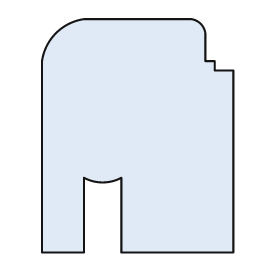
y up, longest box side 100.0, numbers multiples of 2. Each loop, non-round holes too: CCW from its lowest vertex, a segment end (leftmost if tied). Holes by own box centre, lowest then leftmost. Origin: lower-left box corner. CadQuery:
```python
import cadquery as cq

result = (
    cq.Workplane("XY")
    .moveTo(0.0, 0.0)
    .lineTo(18.0, 0.0)
    .lineTo(18.0, 32.0)
    .threePointArc((26.0, 30.0), (34.0, 32.0))
    .lineTo(34.0, 0.0)
    .lineTo(82.0, 0.0)
    .lineTo(82.0, 78.0)
    .lineTo(74.0, 78.0)
    .lineTo(74.0, 82.0)
    .lineTo(70.0, 82.0)
    .lineTo(70.0, 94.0)
    .threePointArc((68.0, 98.0), (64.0, 100.0))
    .lineTo(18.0, 100.0)
    .threePointArc((6.0, 94.0), (0.0, 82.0))
    .close()
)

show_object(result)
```